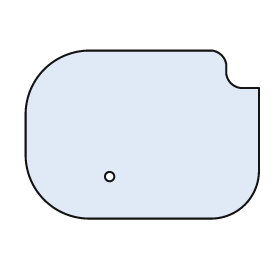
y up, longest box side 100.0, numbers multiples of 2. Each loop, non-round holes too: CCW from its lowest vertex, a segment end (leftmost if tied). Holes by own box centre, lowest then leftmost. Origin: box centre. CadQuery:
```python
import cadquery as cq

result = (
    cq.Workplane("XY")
    .moveTo(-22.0, -36.0)
    .lineTo(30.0, -36.0)
    .threePointArc((44.0, -30.0), (50.0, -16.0))
    .lineTo(50.0, 20.0)
    .lineTo(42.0, 20.0)
    .threePointArc((38.0, 22.0), (36.0, 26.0))
    .lineTo(36.0, 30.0)
    .threePointArc((34.0, 34.0), (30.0, 36.0))
    .lineTo(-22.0, 36.0)
    .threePointArc((-42.0, 28.0), (-50.0, 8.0))
    .lineTo(-50.0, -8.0)
    .threePointArc((-42.0, -28.0), (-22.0, -36.0))
    .close()
    .moveTo(-14.0, -18.0)
    .circle(2.0)
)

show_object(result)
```